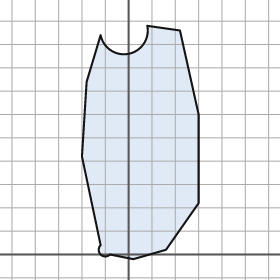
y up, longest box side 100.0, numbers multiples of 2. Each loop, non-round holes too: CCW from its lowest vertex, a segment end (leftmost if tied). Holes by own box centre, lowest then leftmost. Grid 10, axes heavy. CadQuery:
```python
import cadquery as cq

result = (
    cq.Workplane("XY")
    .moveTo(2.0, -2.0)
    .lineTo(16.0, 2.0)
    .lineTo(30.0, 22.0)
    .lineTo(30.0, 60.0)
    .lineTo(22.0, 96.0)
    .lineTo(8.0, 98.0)
    .threePointArc((0.0, 86.0), (-12.0, 94.0))
    .lineTo(-18.0, 74.0)
    .lineTo(-20.0, 42.0)
    .lineTo(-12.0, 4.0)
    .threePointArc((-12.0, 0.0), (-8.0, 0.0))
    .close()
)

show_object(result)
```